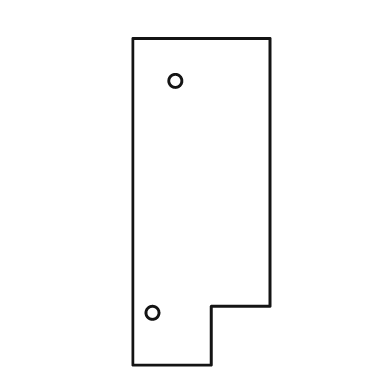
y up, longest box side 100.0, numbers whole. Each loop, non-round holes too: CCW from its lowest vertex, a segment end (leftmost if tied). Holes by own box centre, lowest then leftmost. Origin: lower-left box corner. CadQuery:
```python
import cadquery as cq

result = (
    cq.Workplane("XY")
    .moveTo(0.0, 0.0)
    .lineTo(24.0, 0.0)
    .lineTo(24.0, 18.0)
    .lineTo(42.0, 18.0)
    .lineTo(42.0, 100.0)
    .lineTo(0.0, 100.0)
    .close()
    .moveTo(6.0, 16.0)
    .circle(2.0)
    .moveTo(13.0, 87.0)
    .circle(2.0)
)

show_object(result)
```